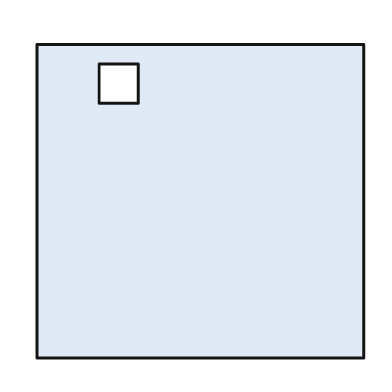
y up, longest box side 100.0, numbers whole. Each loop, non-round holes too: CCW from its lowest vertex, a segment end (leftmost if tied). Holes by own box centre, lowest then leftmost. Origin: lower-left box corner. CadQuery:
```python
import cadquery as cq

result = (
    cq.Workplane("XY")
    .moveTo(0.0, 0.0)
    .lineTo(100.0, 0.0)
    .lineTo(100.0, 96.0)
    .lineTo(0.0, 96.0)
    .close()
    .moveTo(19.0, 78.0)
    .lineTo(31.0, 78.0)
    .lineTo(31.0, 90.0)
    .lineTo(19.0, 90.0)
    .close()
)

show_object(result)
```